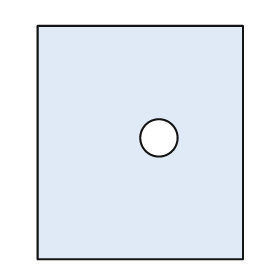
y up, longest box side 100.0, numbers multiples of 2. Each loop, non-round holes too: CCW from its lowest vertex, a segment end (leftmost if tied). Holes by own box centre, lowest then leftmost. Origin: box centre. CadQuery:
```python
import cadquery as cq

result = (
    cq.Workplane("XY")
    .moveTo(-44.0, -50.0)
    .lineTo(44.0, -50.0)
    .lineTo(44.0, 50.0)
    .lineTo(-44.0, 50.0)
    .close()
    .moveTo(8.0, 2.0)
    .circle(8.0)
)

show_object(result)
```